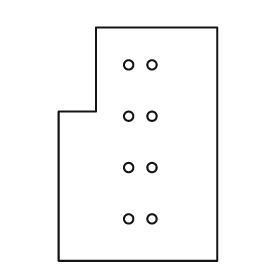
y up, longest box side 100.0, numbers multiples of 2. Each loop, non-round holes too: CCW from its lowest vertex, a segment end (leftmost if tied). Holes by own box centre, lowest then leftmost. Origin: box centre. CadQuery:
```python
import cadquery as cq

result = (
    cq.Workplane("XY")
    .moveTo(-34.0, -50.0)
    .lineTo(34.0, -50.0)
    .lineTo(34.0, 50.0)
    .lineTo(-18.0, 50.0)
    .lineTo(-18.0, 14.0)
    .lineTo(-34.0, 14.0)
    .close()
    .moveTo(-4.0, -32.0)
    .circle(2.0)
    .moveTo(6.0, -32.0)
    .circle(2.0)
    .moveTo(-4.0, -10.0)
    .circle(2.0)
    .moveTo(6.0, -10.0)
    .circle(2.0)
    .moveTo(-4.0, 12.0)
    .circle(2.0)
    .moveTo(6.0, 12.0)
    .circle(2.0)
    .moveTo(-4.0, 34.0)
    .circle(2.0)
    .moveTo(6.0, 34.0)
    .circle(2.0)
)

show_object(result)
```